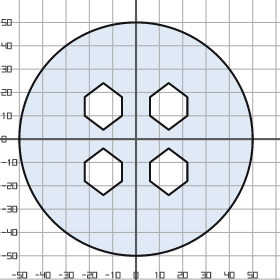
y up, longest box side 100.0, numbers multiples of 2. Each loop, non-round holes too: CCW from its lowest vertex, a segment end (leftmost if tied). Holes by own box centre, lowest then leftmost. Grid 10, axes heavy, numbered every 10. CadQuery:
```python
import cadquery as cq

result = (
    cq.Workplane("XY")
    .moveTo(0.0, 0.0)
    .circle(50.0)
    .moveTo(-14.0, -24.0)
    .lineTo(-6.0, -18.0)
    .lineTo(-6.0, -10.0)
    .lineTo(-14.0, -4.0)
    .lineTo(-22.0, -10.0)
    .lineTo(-22.0, -18.0)
    .close()
    .moveTo(14.0, -24.0)
    .lineTo(22.0, -18.0)
    .lineTo(22.0, -10.0)
    .lineTo(14.0, -4.0)
    .lineTo(6.0, -10.0)
    .lineTo(6.0, -18.0)
    .close()
    .moveTo(-14.0, 4.0)
    .lineTo(-6.0, 10.0)
    .lineTo(-6.0, 18.0)
    .lineTo(-14.0, 24.0)
    .lineTo(-22.0, 18.0)
    .lineTo(-22.0, 10.0)
    .close()
    .moveTo(14.0, 4.0)
    .lineTo(22.0, 10.0)
    .lineTo(22.0, 18.0)
    .lineTo(14.0, 24.0)
    .lineTo(6.0, 18.0)
    .lineTo(6.0, 10.0)
    .close()
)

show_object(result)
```